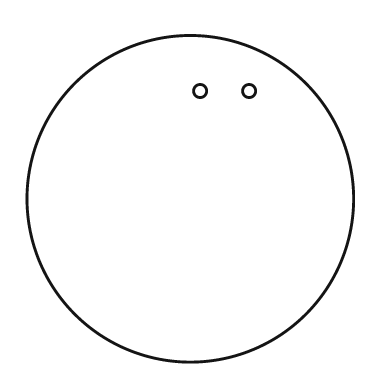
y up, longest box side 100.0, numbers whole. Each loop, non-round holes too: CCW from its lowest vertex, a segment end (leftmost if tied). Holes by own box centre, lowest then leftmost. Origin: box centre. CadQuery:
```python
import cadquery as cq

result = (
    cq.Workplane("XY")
    .moveTo(0.0, 0.0)
    .circle(50.0)
    .moveTo(3.0, 33.0)
    .circle(2.0)
    .moveTo(18.0, 33.0)
    .circle(2.0)
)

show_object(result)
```